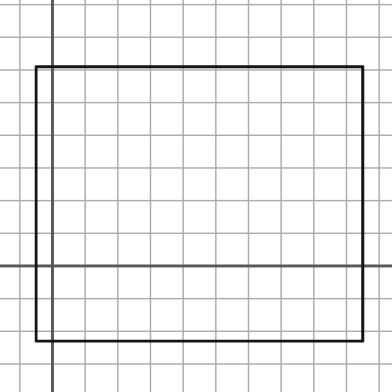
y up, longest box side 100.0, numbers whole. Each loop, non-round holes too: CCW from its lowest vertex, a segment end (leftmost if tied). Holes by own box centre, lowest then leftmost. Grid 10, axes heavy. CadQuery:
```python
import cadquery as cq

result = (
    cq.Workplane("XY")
    .moveTo(-5.0, -23.0)
    .lineTo(95.0, -23.0)
    .lineTo(95.0, 61.0)
    .lineTo(-5.0, 61.0)
    .close()
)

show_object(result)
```